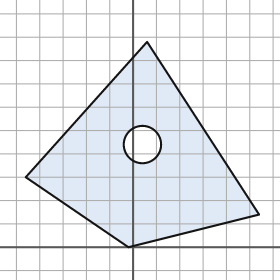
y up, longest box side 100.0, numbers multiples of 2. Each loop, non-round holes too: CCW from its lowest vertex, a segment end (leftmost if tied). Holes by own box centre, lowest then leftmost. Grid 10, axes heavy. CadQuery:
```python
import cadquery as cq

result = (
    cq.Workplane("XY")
    .moveTo(-2.0, 0.0)
    .lineTo(54.0, 14.0)
    .lineTo(6.0, 88.0)
    .lineTo(-46.0, 30.0)
    .close()
    .moveTo(4.0, 44.0)
    .circle(8.0)
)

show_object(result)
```